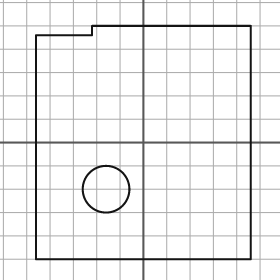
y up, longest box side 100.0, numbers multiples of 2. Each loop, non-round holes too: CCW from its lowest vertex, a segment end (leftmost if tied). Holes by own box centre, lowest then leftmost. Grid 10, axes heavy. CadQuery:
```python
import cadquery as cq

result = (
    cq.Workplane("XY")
    .moveTo(-46.0, -50.0)
    .lineTo(46.0, -50.0)
    .lineTo(46.0, 50.0)
    .lineTo(-22.0, 50.0)
    .lineTo(-22.0, 46.0)
    .lineTo(-46.0, 46.0)
    .close()
    .moveTo(-16.0, -20.0)
    .circle(10.0)
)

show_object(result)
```